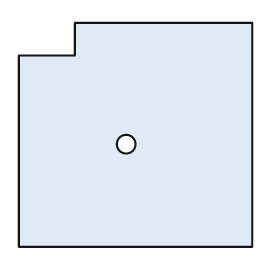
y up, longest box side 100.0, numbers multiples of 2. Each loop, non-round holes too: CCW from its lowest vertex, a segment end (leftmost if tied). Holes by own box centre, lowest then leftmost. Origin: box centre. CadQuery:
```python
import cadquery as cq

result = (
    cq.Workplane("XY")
    .moveTo(-50.0, -48.0)
    .lineTo(50.0, -48.0)
    .lineTo(50.0, 48.0)
    .lineTo(-26.0, 48.0)
    .lineTo(-26.0, 34.0)
    .lineTo(-50.0, 34.0)
    .close()
    .moveTo(-4.0, -4.0)
    .circle(4.0)
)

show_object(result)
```